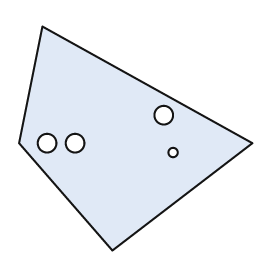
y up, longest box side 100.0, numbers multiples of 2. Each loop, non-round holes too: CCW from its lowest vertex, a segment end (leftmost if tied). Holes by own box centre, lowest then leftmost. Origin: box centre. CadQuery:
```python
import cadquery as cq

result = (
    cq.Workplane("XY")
    .moveTo(-10.0, -48.0)
    .lineTo(50.0, -2.0)
    .lineTo(-40.0, 48.0)
    .lineTo(-50.0, -2.0)
    .close()
    .moveTo(16.0, -6.0)
    .circle(2.0)
    .moveTo(-38.0, -2.0)
    .circle(4.0)
    .moveTo(-26.0, -2.0)
    .circle(4.0)
    .moveTo(12.0, 10.0)
    .circle(4.0)
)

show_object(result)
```